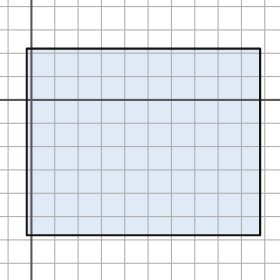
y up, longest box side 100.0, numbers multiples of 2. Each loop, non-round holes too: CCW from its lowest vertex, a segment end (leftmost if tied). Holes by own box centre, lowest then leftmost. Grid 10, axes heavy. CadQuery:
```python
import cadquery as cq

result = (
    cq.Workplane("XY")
    .moveTo(-2.0, -58.0)
    .lineTo(98.0, -58.0)
    .lineTo(98.0, 22.0)
    .lineTo(-2.0, 22.0)
    .close()
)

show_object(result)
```